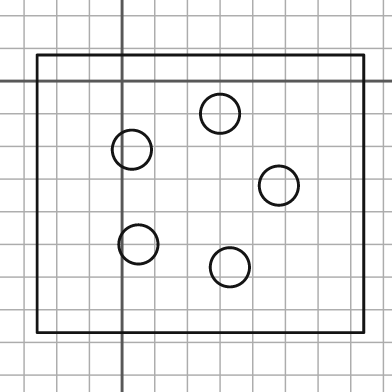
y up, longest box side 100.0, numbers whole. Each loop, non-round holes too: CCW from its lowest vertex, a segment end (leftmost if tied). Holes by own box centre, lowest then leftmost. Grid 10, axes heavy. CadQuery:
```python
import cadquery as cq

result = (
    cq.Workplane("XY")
    .moveTo(-26.0, -77.0)
    .lineTo(74.0, -77.0)
    .lineTo(74.0, 8.0)
    .lineTo(-26.0, 8.0)
    .close()
    .moveTo(33.0, -57.0)
    .circle(6.0)
    .moveTo(5.0, -50.0)
    .circle(6.0)
    .moveTo(48.0, -32.0)
    .circle(6.0)
    .moveTo(3.0, -21.0)
    .circle(6.0)
    .moveTo(30.0, -10.0)
    .circle(6.0)
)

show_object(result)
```